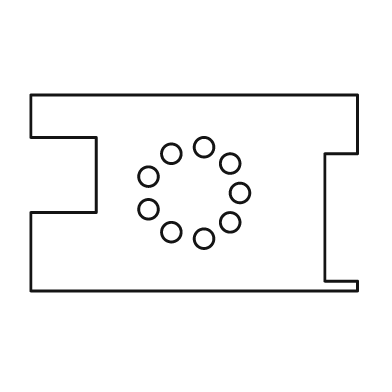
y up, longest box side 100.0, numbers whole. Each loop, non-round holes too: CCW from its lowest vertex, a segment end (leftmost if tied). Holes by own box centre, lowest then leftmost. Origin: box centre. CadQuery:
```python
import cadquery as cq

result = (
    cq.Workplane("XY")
    .moveTo(-50.0, -30.0)
    .lineTo(50.0, -30.0)
    .lineTo(50.0, -27.0)
    .lineTo(40.0, -27.0)
    .lineTo(40.0, 12.0)
    .lineTo(50.0, 12.0)
    .lineTo(50.0, 30.0)
    .lineTo(-50.0, 30.0)
    .lineTo(-50.0, 17.0)
    .lineTo(-30.0, 17.0)
    .lineTo(-30.0, -6.0)
    .lineTo(-50.0, -6.0)
    .close()
    .moveTo(3.0, -14.0)
    .circle(3.0)
    .moveTo(-7.0, -12.0)
    .circle(3.0)
    .moveTo(11.0, -9.0)
    .circle(3.0)
    .moveTo(-14.0, -5.0)
    .circle(3.0)
    .moveTo(14.0, 0.0)
    .circle(3.0)
    .moveTo(-14.0, 5.0)
    .circle(3.0)
    .moveTo(11.0, 9.0)
    .circle(3.0)
    .moveTo(-7.0, 12.0)
    .circle(3.0)
    .moveTo(3.0, 14.0)
    .circle(3.0)
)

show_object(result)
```